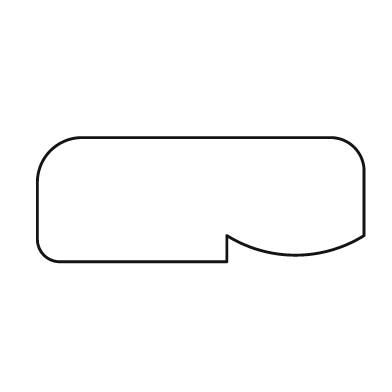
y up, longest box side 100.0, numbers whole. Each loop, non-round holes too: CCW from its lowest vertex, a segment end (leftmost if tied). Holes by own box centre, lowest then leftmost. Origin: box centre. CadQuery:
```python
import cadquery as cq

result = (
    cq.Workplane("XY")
    .moveTo(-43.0, -19.0)
    .lineTo(8.0, -19.0)
    .lineTo(8.0, -11.0)
    .threePointArc((29.0, -17.0), (50.0, -11.0))
    .lineTo(50.0, 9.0)
    .threePointArc((47.0, 16.0), (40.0, 19.0))
    .lineTo(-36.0, 19.0)
    .threePointArc((-46.0, 15.0), (-50.0, 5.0))
    .lineTo(-50.0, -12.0)
    .threePointArc((-48.0, -17.0), (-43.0, -19.0))
    .close()
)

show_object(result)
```